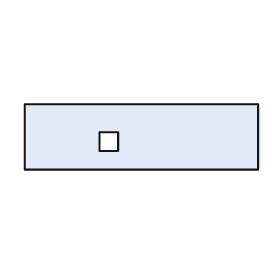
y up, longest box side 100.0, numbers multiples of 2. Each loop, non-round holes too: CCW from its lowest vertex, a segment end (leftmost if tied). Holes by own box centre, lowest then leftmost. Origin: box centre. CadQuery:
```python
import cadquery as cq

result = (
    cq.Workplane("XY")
    .moveTo(-50.0, -14.0)
    .lineTo(50.0, -14.0)
    .lineTo(50.0, 14.0)
    .lineTo(-50.0, 14.0)
    .close()
    .moveTo(-18.0, -6.0)
    .lineTo(-10.0, -6.0)
    .lineTo(-10.0, 2.0)
    .lineTo(-18.0, 2.0)
    .close()
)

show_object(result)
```